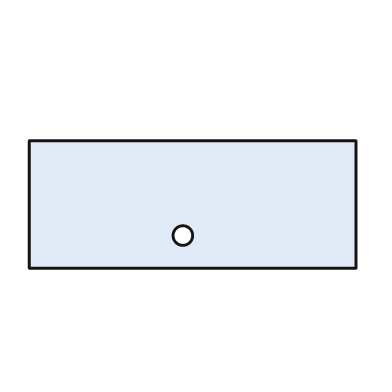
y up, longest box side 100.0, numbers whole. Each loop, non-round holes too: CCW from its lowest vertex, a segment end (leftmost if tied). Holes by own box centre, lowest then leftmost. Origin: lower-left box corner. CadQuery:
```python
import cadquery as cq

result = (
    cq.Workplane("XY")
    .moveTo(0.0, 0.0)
    .lineTo(100.0, 0.0)
    .lineTo(100.0, 39.0)
    .lineTo(0.0, 39.0)
    .close()
    .moveTo(47.0, 10.0)
    .circle(3.0)
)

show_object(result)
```